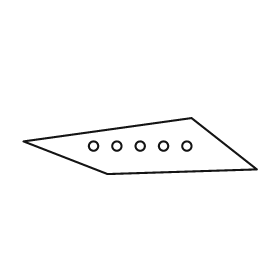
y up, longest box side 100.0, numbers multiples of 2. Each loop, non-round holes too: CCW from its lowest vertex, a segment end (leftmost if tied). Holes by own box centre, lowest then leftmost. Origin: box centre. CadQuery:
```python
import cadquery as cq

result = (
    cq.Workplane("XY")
    .moveTo(-14.0, -12.0)
    .lineTo(50.0, -10.0)
    .lineTo(22.0, 12.0)
    .lineTo(-50.0, 2.0)
    .close()
    .moveTo(-20.0, 0.0)
    .circle(2.0)
    .moveTo(-10.0, 0.0)
    .circle(2.0)
    .moveTo(0.0, 0.0)
    .circle(2.0)
    .moveTo(10.0, 0.0)
    .circle(2.0)
    .moveTo(20.0, 0.0)
    .circle(2.0)
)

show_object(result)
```